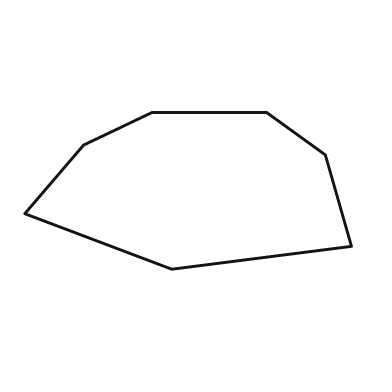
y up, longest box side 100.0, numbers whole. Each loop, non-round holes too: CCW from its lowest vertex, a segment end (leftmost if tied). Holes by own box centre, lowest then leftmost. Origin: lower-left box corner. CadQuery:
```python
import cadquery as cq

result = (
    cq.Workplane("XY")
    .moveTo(45.0, 0.0)
    .lineTo(100.0, 7.0)
    .lineTo(92.0, 35.0)
    .lineTo(74.0, 48.0)
    .lineTo(39.0, 48.0)
    .lineTo(18.0, 38.0)
    .lineTo(0.0, 17.0)
    .close()
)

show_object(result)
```